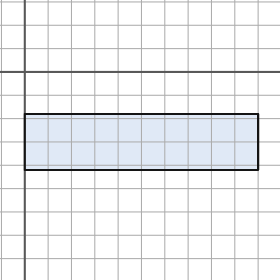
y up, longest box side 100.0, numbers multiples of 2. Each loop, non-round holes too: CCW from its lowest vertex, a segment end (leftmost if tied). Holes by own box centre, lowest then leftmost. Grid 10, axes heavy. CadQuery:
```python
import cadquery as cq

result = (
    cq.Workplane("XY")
    .moveTo(0.0, -42.0)
    .lineTo(100.0, -42.0)
    .lineTo(100.0, -18.0)
    .lineTo(0.0, -18.0)
    .close()
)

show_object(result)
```